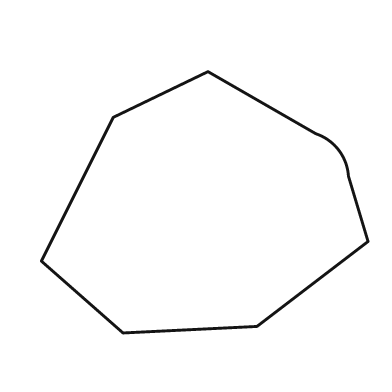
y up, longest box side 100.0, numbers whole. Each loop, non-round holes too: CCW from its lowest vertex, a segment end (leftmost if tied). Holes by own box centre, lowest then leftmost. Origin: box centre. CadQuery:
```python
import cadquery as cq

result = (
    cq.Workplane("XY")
    .moveTo(-25.0, -40.0)
    .lineTo(16.0, -38.0)
    .lineTo(50.0, -12.0)
    .lineTo(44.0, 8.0)
    .threePointArc((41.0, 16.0), (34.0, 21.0))
    .lineTo(1.0, 40.0)
    .lineTo(-28.0, 26.0)
    .lineTo(-50.0, -18.0)
    .close()
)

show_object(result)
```